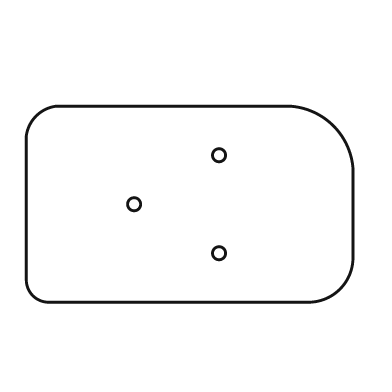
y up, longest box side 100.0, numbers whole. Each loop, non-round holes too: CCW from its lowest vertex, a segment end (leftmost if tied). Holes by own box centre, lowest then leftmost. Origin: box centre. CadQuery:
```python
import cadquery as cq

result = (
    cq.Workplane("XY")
    .moveTo(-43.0, -30.0)
    .lineTo(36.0, -30.0)
    .threePointArc((46.0, -26.0), (50.0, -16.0))
    .lineTo(50.0, 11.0)
    .threePointArc((44.0, 24.0), (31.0, 30.0))
    .lineTo(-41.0, 30.0)
    .threePointArc((-47.0, 27.0), (-50.0, 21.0))
    .lineTo(-50.0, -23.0)
    .threePointArc((-48.0, -28.0), (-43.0, -30.0))
    .close()
    .moveTo(9.0, -15.0)
    .circle(2.0)
    .moveTo(-17.0, 0.0)
    .circle(2.0)
    .moveTo(9.0, 15.0)
    .circle(2.0)
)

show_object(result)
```